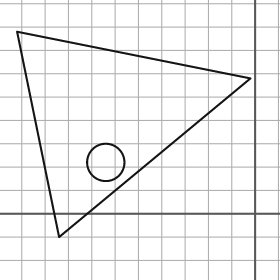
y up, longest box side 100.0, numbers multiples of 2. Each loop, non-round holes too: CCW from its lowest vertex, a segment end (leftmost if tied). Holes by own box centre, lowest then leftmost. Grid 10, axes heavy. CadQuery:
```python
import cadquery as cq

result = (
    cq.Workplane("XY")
    .moveTo(-84.0, -10.0)
    .lineTo(-2.0, 58.0)
    .lineTo(-102.0, 78.0)
    .close()
    .moveTo(-64.0, 22.0)
    .circle(8.0)
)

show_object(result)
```